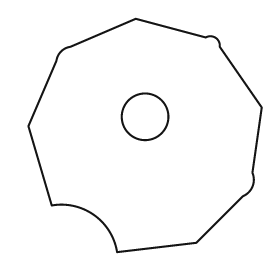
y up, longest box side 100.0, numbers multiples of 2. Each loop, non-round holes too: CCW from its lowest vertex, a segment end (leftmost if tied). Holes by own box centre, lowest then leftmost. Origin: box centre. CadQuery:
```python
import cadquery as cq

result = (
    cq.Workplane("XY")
    .moveTo(-12.0, -50.0)
    .lineTo(22.0, -46.0)
    .lineTo(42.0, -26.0)
    .threePointArc((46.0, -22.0), (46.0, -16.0))
    .lineTo(50.0, 12.0)
    .lineTo(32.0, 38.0)
    .threePointArc((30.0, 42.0), (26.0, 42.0))
    .lineTo(-4.0, 50.0)
    .lineTo(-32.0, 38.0)
    .threePointArc((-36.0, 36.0), (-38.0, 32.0))
    .lineTo(-50.0, 4.0)
    .lineTo(-40.0, -30.0)
    .threePointArc((-22.0, -34.0), (-12.0, -50.0))
    .close()
    .moveTo(0.0, 8.0)
    .circle(10.0)
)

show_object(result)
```